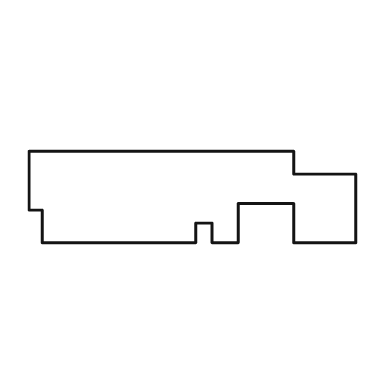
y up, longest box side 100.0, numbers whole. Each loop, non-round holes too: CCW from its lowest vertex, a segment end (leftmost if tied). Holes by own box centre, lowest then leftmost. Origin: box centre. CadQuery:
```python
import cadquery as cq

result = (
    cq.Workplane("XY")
    .moveTo(-46.0, -14.0)
    .lineTo(1.0, -14.0)
    .lineTo(1.0, -8.0)
    .lineTo(6.0, -8.0)
    .lineTo(6.0, -14.0)
    .lineTo(14.0, -14.0)
    .lineTo(14.0, -2.0)
    .lineTo(31.0, -2.0)
    .lineTo(31.0, -14.0)
    .lineTo(50.0, -14.0)
    .lineTo(50.0, 7.0)
    .lineTo(31.0, 7.0)
    .lineTo(31.0, 14.0)
    .lineTo(-50.0, 14.0)
    .lineTo(-50.0, -4.0)
    .lineTo(-46.0, -4.0)
    .close()
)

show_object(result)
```